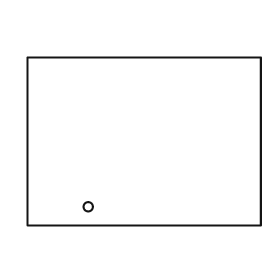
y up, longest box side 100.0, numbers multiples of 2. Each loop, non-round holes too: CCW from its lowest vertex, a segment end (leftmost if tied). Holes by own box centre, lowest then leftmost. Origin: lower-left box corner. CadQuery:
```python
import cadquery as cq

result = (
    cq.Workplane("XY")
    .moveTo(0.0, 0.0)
    .lineTo(100.0, 0.0)
    .lineTo(100.0, 72.0)
    .lineTo(0.0, 72.0)
    .close()
    .moveTo(26.0, 8.0)
    .circle(2.0)
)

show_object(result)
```